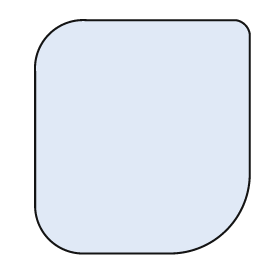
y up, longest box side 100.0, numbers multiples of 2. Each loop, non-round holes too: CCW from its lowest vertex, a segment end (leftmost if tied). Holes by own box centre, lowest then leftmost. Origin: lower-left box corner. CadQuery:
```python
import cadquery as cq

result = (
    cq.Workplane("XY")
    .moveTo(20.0, 0.0)
    .lineTo(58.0, 0.0)
    .threePointArc((82.0, 10.0), (92.0, 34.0))
    .lineTo(92.0, 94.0)
    .threePointArc((90.0, 98.0), (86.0, 100.0))
    .lineTo(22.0, 100.0)
    .threePointArc((6.0, 94.0), (0.0, 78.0))
    .lineTo(0.0, 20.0)
    .threePointArc((6.0, 6.0), (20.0, 0.0))
    .close()
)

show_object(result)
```